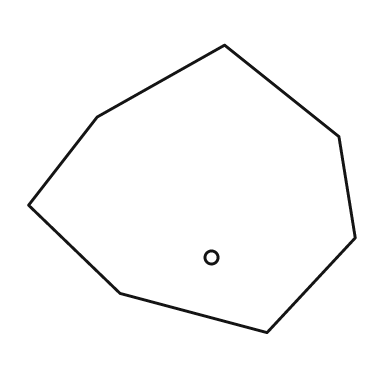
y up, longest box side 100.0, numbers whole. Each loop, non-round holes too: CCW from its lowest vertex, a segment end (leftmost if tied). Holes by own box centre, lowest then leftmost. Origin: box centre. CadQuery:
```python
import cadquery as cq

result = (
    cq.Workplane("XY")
    .moveTo(23.0, -44.0)
    .lineTo(50.0, -15.0)
    .lineTo(45.0, 16.0)
    .lineTo(10.0, 44.0)
    .lineTo(-29.0, 22.0)
    .lineTo(-50.0, -5.0)
    .lineTo(-22.0, -32.0)
    .close()
    .moveTo(6.0, -21.0)
    .circle(2.0)
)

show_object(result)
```